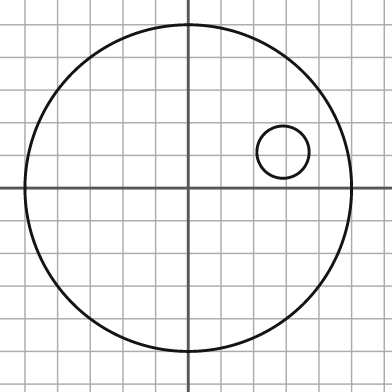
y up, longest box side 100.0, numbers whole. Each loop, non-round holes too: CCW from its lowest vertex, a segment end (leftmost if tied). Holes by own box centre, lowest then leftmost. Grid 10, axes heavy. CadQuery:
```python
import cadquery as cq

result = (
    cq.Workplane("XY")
    .moveTo(0.0, 0.0)
    .circle(50.0)
    .moveTo(29.0, 11.0)
    .circle(8.0)
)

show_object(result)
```